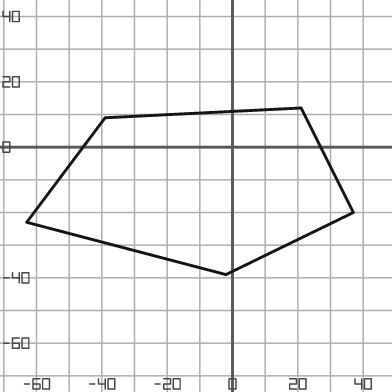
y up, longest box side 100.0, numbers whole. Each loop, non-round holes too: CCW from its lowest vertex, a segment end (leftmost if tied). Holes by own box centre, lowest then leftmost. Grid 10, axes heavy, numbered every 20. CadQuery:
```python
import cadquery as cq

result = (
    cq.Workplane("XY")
    .moveTo(-2.0, -39.0)
    .lineTo(37.0, -20.0)
    .lineTo(21.0, 12.0)
    .lineTo(-39.0, 9.0)
    .lineTo(-63.0, -23.0)
    .close()
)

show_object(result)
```